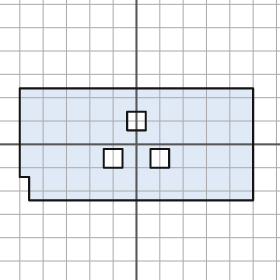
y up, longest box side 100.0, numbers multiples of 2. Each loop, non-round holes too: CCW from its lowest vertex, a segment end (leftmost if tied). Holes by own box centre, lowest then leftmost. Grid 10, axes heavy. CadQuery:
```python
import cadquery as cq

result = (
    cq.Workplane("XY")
    .moveTo(-46.0, -24.0)
    .lineTo(50.0, -24.0)
    .lineTo(50.0, 24.0)
    .lineTo(-50.0, 24.0)
    .lineTo(-50.0, -14.0)
    .lineTo(-46.0, -14.0)
    .close()
    .moveTo(-14.0, -10.0)
    .lineTo(-6.0, -10.0)
    .lineTo(-6.0, -2.0)
    .lineTo(-14.0, -2.0)
    .close()
    .moveTo(6.0, -10.0)
    .lineTo(14.0, -10.0)
    .lineTo(14.0, -2.0)
    .lineTo(6.0, -2.0)
    .close()
    .moveTo(-4.0, 6.0)
    .lineTo(4.0, 6.0)
    .lineTo(4.0, 14.0)
    .lineTo(-4.0, 14.0)
    .close()
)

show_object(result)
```